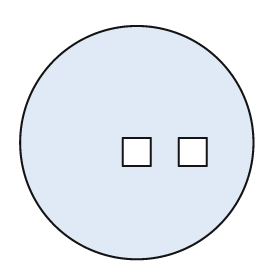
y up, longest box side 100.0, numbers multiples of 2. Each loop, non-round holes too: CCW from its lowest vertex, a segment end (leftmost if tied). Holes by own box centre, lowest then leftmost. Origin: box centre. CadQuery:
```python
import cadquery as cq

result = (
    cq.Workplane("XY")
    .moveTo(0.0, 0.0)
    .circle(50.0)
    .moveTo(-6.0, -10.0)
    .lineTo(6.0, -10.0)
    .lineTo(6.0, 2.0)
    .lineTo(-6.0, 2.0)
    .close()
    .moveTo(18.0, -10.0)
    .lineTo(30.0, -10.0)
    .lineTo(30.0, 2.0)
    .lineTo(18.0, 2.0)
    .close()
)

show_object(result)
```